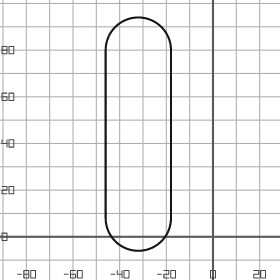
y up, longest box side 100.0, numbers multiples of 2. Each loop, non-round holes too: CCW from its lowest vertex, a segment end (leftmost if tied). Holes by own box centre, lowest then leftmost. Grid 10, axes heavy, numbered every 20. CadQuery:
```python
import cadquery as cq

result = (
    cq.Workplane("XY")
    .moveTo(-46.0, 8.0)
    .threePointArc((-32.0, -6.0), (-18.0, 8.0))
    .lineTo(-18.0, 80.0)
    .threePointArc((-32.0, 94.0), (-46.0, 80.0))
    .close()
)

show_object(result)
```